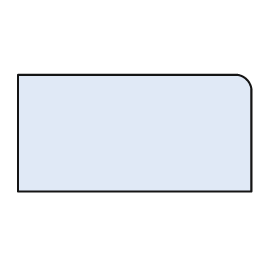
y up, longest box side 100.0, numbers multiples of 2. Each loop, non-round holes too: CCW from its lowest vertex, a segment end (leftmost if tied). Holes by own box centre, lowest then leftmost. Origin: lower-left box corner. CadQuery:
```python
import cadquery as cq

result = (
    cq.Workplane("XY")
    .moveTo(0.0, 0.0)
    .lineTo(100.0, 0.0)
    .lineTo(100.0, 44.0)
    .threePointArc((98.0, 48.0), (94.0, 50.0))
    .lineTo(0.0, 50.0)
    .close()
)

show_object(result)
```